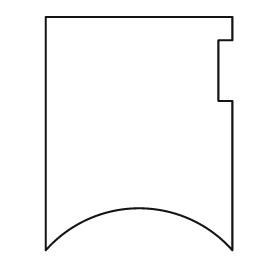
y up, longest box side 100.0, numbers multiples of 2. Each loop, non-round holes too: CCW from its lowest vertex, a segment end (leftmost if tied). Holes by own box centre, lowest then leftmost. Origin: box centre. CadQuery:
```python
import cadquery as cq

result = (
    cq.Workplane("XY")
    .moveTo(-40.0, -50.0)
    .threePointArc((0.0, -32.0), (40.0, -50.0))
    .lineTo(40.0, 14.0)
    .lineTo(34.0, 14.0)
    .lineTo(34.0, 40.0)
    .lineTo(40.0, 40.0)
    .lineTo(40.0, 50.0)
    .lineTo(-40.0, 50.0)
    .close()
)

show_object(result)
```